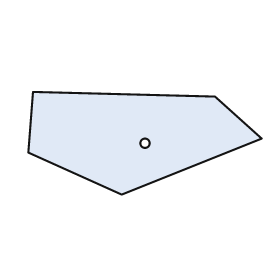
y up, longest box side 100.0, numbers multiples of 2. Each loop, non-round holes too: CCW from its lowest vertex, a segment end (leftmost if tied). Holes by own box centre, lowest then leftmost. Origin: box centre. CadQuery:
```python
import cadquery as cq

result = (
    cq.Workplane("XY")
    .moveTo(-10.0, -22.0)
    .lineTo(50.0, 2.0)
    .lineTo(30.0, 20.0)
    .lineTo(-48.0, 22.0)
    .lineTo(-50.0, -4.0)
    .close()
    .moveTo(0.0, 0.0)
    .circle(2.0)
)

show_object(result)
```